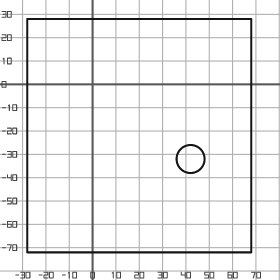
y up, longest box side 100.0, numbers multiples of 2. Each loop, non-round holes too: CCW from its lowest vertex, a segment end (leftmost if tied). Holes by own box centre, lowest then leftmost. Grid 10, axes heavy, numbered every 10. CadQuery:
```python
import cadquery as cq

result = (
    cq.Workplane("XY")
    .moveTo(-28.0, -72.0)
    .lineTo(68.0, -72.0)
    .lineTo(68.0, 28.0)
    .lineTo(-28.0, 28.0)
    .close()
    .moveTo(42.0, -32.0)
    .circle(6.0)
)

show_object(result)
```